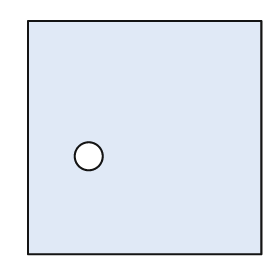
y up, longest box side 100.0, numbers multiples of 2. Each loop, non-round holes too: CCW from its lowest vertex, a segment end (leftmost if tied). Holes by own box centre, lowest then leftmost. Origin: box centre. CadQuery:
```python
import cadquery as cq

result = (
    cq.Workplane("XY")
    .moveTo(-50.0, -50.0)
    .lineTo(50.0, -50.0)
    .lineTo(50.0, 50.0)
    .lineTo(-50.0, 50.0)
    .close()
    .moveTo(-24.0, -8.0)
    .circle(6.0)
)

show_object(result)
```